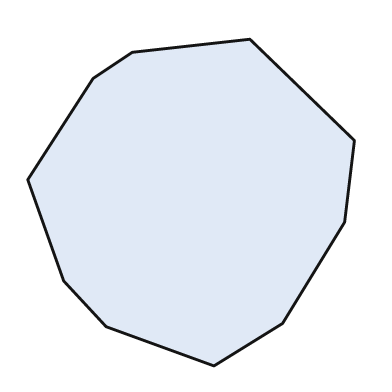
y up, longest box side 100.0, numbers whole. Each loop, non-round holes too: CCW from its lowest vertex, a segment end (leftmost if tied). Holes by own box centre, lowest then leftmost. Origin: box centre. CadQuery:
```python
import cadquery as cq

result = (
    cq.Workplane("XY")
    .moveTo(7.0, -50.0)
    .lineTo(28.0, -37.0)
    .lineTo(47.0, -6.0)
    .lineTo(50.0, 19.0)
    .lineTo(18.0, 50.0)
    .lineTo(-18.0, 46.0)
    .lineTo(-30.0, 38.0)
    .lineTo(-50.0, 7.0)
    .lineTo(-39.0, -24.0)
    .lineTo(-26.0, -38.0)
    .close()
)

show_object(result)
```